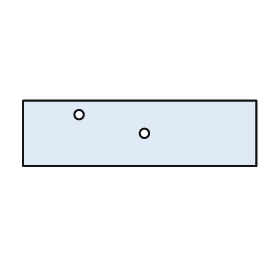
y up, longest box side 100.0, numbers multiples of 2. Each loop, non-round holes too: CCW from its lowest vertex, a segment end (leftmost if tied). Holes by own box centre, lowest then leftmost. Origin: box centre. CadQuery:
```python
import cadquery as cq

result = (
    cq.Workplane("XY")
    .moveTo(-50.0, -14.0)
    .lineTo(50.0, -14.0)
    .lineTo(50.0, 14.0)
    .lineTo(-50.0, 14.0)
    .close()
    .moveTo(2.0, 0.0)
    .circle(2.0)
    .moveTo(-26.0, 8.0)
    .circle(2.0)
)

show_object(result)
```